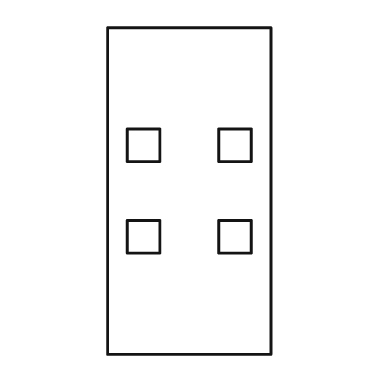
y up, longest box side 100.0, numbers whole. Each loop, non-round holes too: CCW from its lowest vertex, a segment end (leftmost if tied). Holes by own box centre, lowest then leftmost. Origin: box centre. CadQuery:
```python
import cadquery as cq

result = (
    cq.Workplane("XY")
    .moveTo(-25.0, -50.0)
    .lineTo(25.0, -50.0)
    .lineTo(25.0, 50.0)
    .lineTo(-25.0, 50.0)
    .close()
    .moveTo(-19.0, -19.0)
    .lineTo(-9.0, -19.0)
    .lineTo(-9.0, -9.0)
    .lineTo(-19.0, -9.0)
    .close()
    .moveTo(9.0, -19.0)
    .lineTo(19.0, -19.0)
    .lineTo(19.0, -9.0)
    .lineTo(9.0, -9.0)
    .close()
    .moveTo(-19.0, 9.0)
    .lineTo(-9.0, 9.0)
    .lineTo(-9.0, 19.0)
    .lineTo(-19.0, 19.0)
    .close()
    .moveTo(9.0, 9.0)
    .lineTo(19.0, 9.0)
    .lineTo(19.0, 19.0)
    .lineTo(9.0, 19.0)
    .close()
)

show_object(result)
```